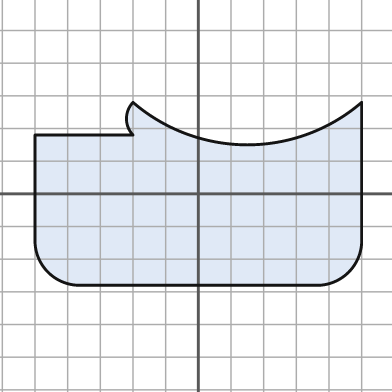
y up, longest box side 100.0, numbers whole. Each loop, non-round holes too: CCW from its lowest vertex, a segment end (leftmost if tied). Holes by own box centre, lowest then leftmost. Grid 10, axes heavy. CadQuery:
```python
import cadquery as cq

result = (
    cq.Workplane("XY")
    .moveTo(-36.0, -28.0)
    .lineTo(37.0, -28.0)
    .threePointArc((46.0, -24.0), (50.0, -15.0))
    .lineTo(50.0, 28.0)
    .threePointArc((15.0, 15.0), (-20.0, 28.0))
    .threePointArc((-22.0, 23.0), (-20.0, 18.0))
    .lineTo(-50.0, 18.0)
    .lineTo(-50.0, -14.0)
    .threePointArc((-46.0, -24.0), (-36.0, -28.0))
    .close()
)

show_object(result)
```